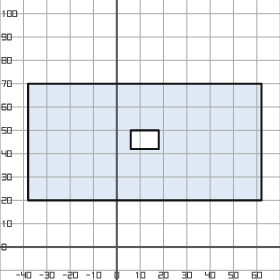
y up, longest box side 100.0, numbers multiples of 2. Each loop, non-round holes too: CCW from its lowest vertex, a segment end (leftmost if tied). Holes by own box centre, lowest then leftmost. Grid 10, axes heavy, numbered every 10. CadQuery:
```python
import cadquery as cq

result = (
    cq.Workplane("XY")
    .moveTo(-38.0, 20.0)
    .lineTo(62.0, 20.0)
    .lineTo(62.0, 70.0)
    .lineTo(-38.0, 70.0)
    .close()
    .moveTo(6.0, 42.0)
    .lineTo(18.0, 42.0)
    .lineTo(18.0, 50.0)
    .lineTo(6.0, 50.0)
    .close()
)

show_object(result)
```